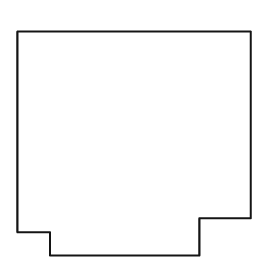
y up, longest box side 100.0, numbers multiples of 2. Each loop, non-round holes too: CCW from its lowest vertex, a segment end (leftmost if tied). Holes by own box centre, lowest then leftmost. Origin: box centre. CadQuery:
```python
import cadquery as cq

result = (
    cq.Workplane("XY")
    .moveTo(-36.0, -48.0)
    .lineTo(28.0, -48.0)
    .lineTo(28.0, -32.0)
    .lineTo(50.0, -32.0)
    .lineTo(50.0, 48.0)
    .lineTo(-50.0, 48.0)
    .lineTo(-50.0, -38.0)
    .lineTo(-36.0, -38.0)
    .close()
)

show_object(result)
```